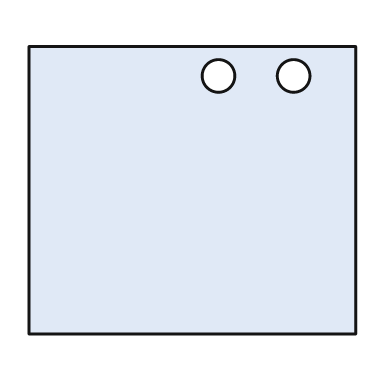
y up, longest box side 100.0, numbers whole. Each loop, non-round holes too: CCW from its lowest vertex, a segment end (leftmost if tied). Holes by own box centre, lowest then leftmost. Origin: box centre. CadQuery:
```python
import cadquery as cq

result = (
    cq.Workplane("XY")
    .moveTo(-50.0, -44.0)
    .lineTo(50.0, -44.0)
    .lineTo(50.0, 44.0)
    .lineTo(-50.0, 44.0)
    .close()
    .moveTo(8.0, 35.0)
    .circle(5.0)
    .moveTo(31.0, 35.0)
    .circle(5.0)
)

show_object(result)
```